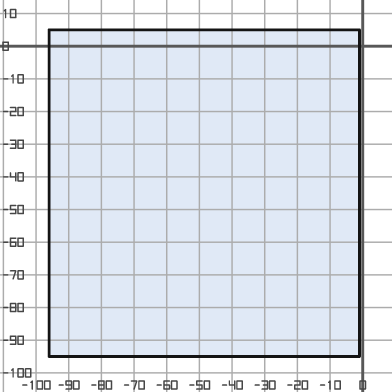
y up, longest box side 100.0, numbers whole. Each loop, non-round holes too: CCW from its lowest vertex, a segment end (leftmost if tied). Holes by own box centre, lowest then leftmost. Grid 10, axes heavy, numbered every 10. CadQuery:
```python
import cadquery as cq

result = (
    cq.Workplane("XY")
    .moveTo(-96.0, -95.0)
    .lineTo(-1.0, -95.0)
    .lineTo(-1.0, 5.0)
    .lineTo(-96.0, 5.0)
    .close()
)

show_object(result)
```